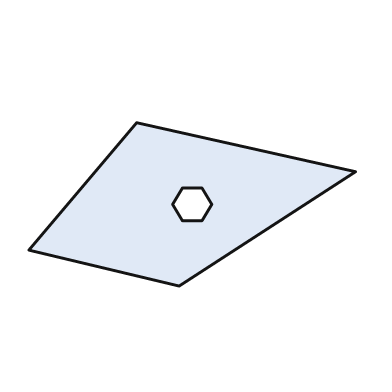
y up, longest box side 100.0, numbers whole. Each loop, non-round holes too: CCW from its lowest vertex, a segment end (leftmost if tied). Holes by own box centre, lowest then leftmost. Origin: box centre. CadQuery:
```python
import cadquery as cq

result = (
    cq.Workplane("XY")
    .moveTo(-4.0, -25.0)
    .lineTo(50.0, 10.0)
    .lineTo(-17.0, 25.0)
    .lineTo(-50.0, -14.0)
    .close()
    .moveTo(-3.0, -5.0)
    .lineTo(3.0, -5.0)
    .lineTo(6.0, 0.0)
    .lineTo(3.0, 5.0)
    .lineTo(-3.0, 5.0)
    .lineTo(-6.0, 0.0)
    .close()
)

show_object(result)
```